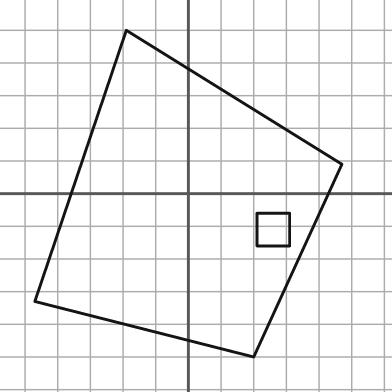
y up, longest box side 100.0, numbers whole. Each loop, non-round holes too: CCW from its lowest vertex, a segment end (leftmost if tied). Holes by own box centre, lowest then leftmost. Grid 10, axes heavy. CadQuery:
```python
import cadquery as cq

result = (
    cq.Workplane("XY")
    .moveTo(20.0, -50.0)
    .lineTo(47.0, 9.0)
    .lineTo(-19.0, 50.0)
    .lineTo(-47.0, -33.0)
    .close()
    .moveTo(21.0, -16.0)
    .lineTo(31.0, -16.0)
    .lineTo(31.0, -6.0)
    .lineTo(21.0, -6.0)
    .close()
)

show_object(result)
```